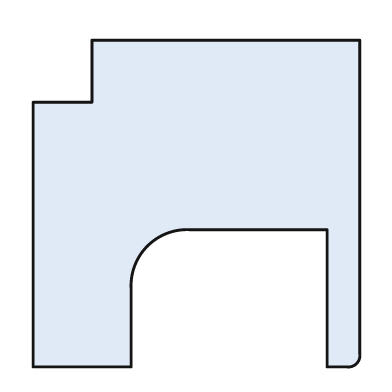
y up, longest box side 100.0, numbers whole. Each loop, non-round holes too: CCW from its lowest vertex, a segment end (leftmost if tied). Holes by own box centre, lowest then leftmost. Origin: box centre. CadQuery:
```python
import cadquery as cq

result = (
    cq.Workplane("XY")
    .moveTo(-50.0, -50.0)
    .lineTo(-20.0, -50.0)
    .lineTo(-20.0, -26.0)
    .threePointArc((-15.0, -13.0), (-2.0, -8.0))
    .lineTo(40.0, -8.0)
    .lineTo(40.0, -50.0)
    .lineTo(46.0, -50.0)
    .threePointArc((49.0, -49.0), (50.0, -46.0))
    .lineTo(50.0, 50.0)
    .lineTo(-32.0, 50.0)
    .lineTo(-32.0, 31.0)
    .lineTo(-50.0, 31.0)
    .close()
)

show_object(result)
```